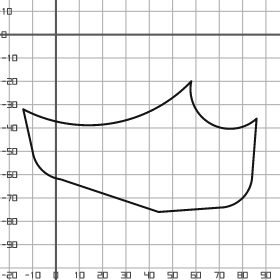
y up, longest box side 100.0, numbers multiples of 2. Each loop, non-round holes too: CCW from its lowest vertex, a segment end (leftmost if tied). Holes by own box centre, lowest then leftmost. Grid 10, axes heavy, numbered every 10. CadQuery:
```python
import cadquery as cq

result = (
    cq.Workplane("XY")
    .moveTo(44.0, -76.0)
    .lineTo(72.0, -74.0)
    .threePointArc((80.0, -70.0), (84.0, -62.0))
    .lineTo(86.0, -36.0)
    .threePointArc((66.0, -38.0), (58.0, -20.0))
    .threePointArc((24.0, -38.0), (-14.0, -32.0))
    .lineTo(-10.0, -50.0)
    .threePointArc((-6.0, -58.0), (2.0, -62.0))
    .close()
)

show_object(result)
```